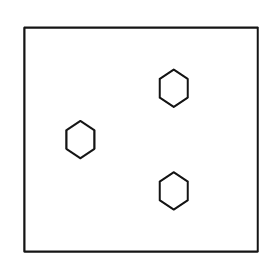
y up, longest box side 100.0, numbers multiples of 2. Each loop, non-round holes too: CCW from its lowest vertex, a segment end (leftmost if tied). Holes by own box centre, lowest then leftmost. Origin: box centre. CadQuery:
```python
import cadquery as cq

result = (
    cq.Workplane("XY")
    .moveTo(-50.0, -48.0)
    .lineTo(50.0, -48.0)
    .lineTo(50.0, 48.0)
    .lineTo(-50.0, 48.0)
    .close()
    .moveTo(14.0, -30.0)
    .lineTo(20.0, -26.0)
    .lineTo(20.0, -18.0)
    .lineTo(14.0, -14.0)
    .lineTo(8.0, -18.0)
    .lineTo(8.0, -26.0)
    .close()
    .moveTo(-26.0, -8.0)
    .lineTo(-20.0, -4.0)
    .lineTo(-20.0, 4.0)
    .lineTo(-26.0, 8.0)
    .lineTo(-32.0, 4.0)
    .lineTo(-32.0, -4.0)
    .close()
    .moveTo(14.0, 14.0)
    .lineTo(20.0, 18.0)
    .lineTo(20.0, 26.0)
    .lineTo(14.0, 30.0)
    .lineTo(8.0, 26.0)
    .lineTo(8.0, 18.0)
    .close()
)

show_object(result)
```